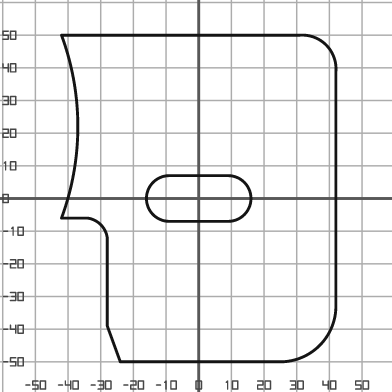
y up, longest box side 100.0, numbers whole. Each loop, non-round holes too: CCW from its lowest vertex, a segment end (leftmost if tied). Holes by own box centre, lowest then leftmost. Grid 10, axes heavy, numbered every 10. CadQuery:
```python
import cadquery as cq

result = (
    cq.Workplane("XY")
    .moveTo(-24.0, -50.0)
    .lineTo(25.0, -50.0)
    .threePointArc((37.0, -45.0), (42.0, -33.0))
    .lineTo(42.0, 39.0)
    .threePointArc((39.0, 47.0), (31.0, 50.0))
    .lineTo(-42.0, 50.0)
    .threePointArc((-37.0, 22.0), (-42.0, -6.0))
    .lineTo(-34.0, -6.0)
    .threePointArc((-30.0, -8.0), (-28.0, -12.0))
    .lineTo(-28.0, -39.0)
    .close()
    .moveTo(-9.0, -7.0)
    .lineTo(9.0, -7.0)
    .threePointArc((16.0, 0.0), (9.0, 7.0))
    .lineTo(-9.0, 7.0)
    .threePointArc((-16.0, 0.0), (-9.0, -7.0))
    .close()
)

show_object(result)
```